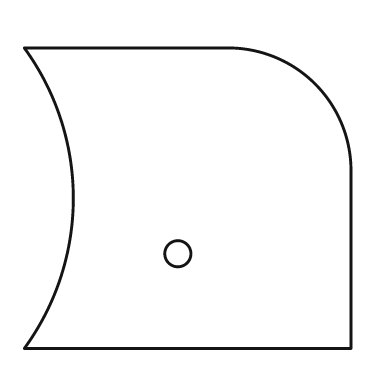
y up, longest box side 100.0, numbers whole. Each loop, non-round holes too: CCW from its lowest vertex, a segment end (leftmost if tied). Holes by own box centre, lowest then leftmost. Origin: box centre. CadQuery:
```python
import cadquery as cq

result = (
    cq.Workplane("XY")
    .moveTo(-50.0, -46.0)
    .lineTo(50.0, -46.0)
    .lineTo(50.0, 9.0)
    .threePointArc((39.0, 35.0), (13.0, 46.0))
    .lineTo(-50.0, 46.0)
    .threePointArc((-35.0, 0.0), (-50.0, -46.0))
    .close()
    .moveTo(-3.0, -17.0)
    .circle(4.0)
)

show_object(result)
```